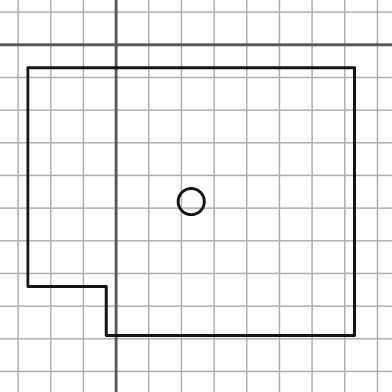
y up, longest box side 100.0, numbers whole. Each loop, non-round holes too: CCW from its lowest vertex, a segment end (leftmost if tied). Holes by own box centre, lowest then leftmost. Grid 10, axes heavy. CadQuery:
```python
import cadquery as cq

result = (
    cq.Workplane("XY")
    .moveTo(-3.0, -89.0)
    .lineTo(73.0, -89.0)
    .lineTo(73.0, -7.0)
    .lineTo(-27.0, -7.0)
    .lineTo(-27.0, -74.0)
    .lineTo(-3.0, -74.0)
    .close()
    .moveTo(23.0, -48.0)
    .circle(4.0)
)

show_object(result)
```